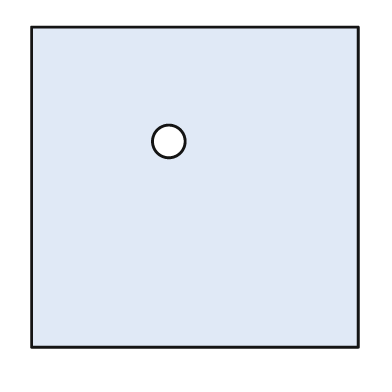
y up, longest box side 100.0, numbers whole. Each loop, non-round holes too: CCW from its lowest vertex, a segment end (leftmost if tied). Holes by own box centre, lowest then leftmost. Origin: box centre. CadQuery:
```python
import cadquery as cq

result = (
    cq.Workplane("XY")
    .moveTo(-50.0, -49.0)
    .lineTo(50.0, -49.0)
    .lineTo(50.0, 49.0)
    .lineTo(-50.0, 49.0)
    .close()
    .moveTo(-8.0, 14.0)
    .circle(5.0)
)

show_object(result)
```